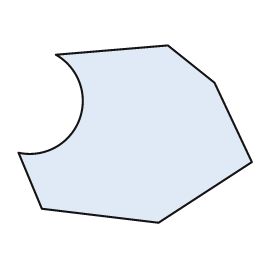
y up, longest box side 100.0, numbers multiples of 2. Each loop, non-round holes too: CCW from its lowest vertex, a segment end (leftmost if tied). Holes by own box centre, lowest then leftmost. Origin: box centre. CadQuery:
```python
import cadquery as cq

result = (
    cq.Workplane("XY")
    .moveTo(10.0, -38.0)
    .lineTo(50.0, -12.0)
    .lineTo(34.0, 22.0)
    .lineTo(14.0, 38.0)
    .lineTo(-34.0, 34.0)
    .threePointArc((-24.0, 6.0), (-50.0, -8.0))
    .lineTo(-40.0, -32.0)
    .close()
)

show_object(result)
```